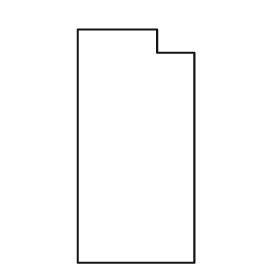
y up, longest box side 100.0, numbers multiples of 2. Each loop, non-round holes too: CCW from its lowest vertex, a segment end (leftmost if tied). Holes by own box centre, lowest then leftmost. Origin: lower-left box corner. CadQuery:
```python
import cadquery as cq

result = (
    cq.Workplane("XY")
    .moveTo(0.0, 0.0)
    .lineTo(50.0, 0.0)
    .lineTo(50.0, 90.0)
    .lineTo(34.0, 90.0)
    .lineTo(34.0, 100.0)
    .lineTo(0.0, 100.0)
    .close()
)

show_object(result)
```